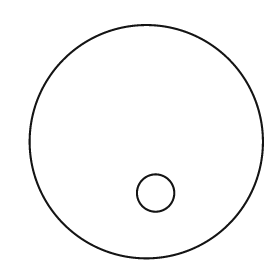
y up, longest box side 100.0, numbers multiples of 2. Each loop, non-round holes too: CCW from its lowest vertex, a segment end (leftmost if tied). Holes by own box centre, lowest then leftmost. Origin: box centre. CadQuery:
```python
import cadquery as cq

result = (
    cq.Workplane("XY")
    .moveTo(0.0, 0.0)
    .circle(50.0)
    .moveTo(4.0, -22.0)
    .circle(8.0)
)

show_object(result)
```